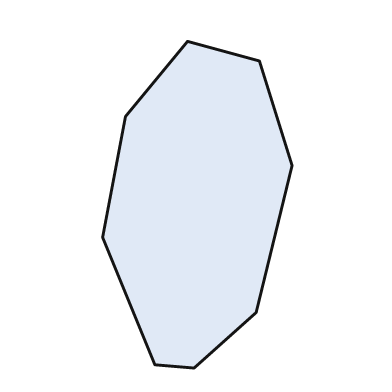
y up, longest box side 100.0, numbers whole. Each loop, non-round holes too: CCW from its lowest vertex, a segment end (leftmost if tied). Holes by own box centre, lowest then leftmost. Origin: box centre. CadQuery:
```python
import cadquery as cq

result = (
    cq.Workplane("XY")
    .moveTo(-1.0, -50.0)
    .lineTo(18.0, -33.0)
    .lineTo(29.0, 12.0)
    .lineTo(19.0, 44.0)
    .lineTo(-3.0, 50.0)
    .lineTo(-22.0, 27.0)
    .lineTo(-29.0, -10.0)
    .lineTo(-13.0, -49.0)
    .close()
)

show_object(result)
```